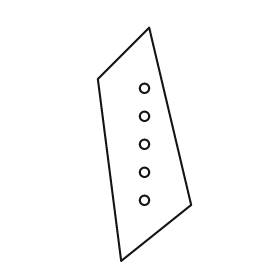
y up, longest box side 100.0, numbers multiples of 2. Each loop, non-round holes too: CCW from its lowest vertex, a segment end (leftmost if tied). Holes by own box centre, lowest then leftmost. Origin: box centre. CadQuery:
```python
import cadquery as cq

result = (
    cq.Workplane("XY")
    .moveTo(-10.0, -50.0)
    .lineTo(20.0, -26.0)
    .lineTo(2.0, 50.0)
    .lineTo(-20.0, 28.0)
    .close()
    .moveTo(0.0, -24.0)
    .circle(2.0)
    .moveTo(0.0, -12.0)
    .circle(2.0)
    .moveTo(0.0, 0.0)
    .circle(2.0)
    .moveTo(0.0, 12.0)
    .circle(2.0)
    .moveTo(0.0, 24.0)
    .circle(2.0)
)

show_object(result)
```